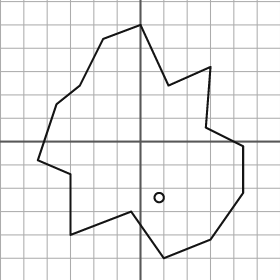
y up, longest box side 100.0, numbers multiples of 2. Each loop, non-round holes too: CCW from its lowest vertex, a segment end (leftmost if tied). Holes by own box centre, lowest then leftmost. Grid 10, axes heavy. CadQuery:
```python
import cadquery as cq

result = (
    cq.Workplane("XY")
    .moveTo(10.0, -50.0)
    .lineTo(30.0, -42.0)
    .lineTo(44.0, -22.0)
    .lineTo(44.0, -2.0)
    .lineTo(28.0, 6.0)
    .lineTo(30.0, 32.0)
    .lineTo(12.0, 24.0)
    .lineTo(0.0, 50.0)
    .lineTo(-16.0, 44.0)
    .lineTo(-26.0, 24.0)
    .lineTo(-36.0, 16.0)
    .lineTo(-44.0, -8.0)
    .lineTo(-30.0, -14.0)
    .lineTo(-30.0, -40.0)
    .lineTo(-4.0, -30.0)
    .close()
    .moveTo(8.0, -24.0)
    .circle(2.0)
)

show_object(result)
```